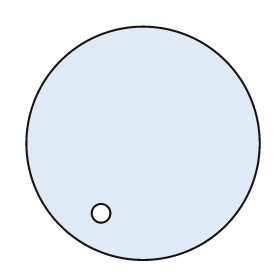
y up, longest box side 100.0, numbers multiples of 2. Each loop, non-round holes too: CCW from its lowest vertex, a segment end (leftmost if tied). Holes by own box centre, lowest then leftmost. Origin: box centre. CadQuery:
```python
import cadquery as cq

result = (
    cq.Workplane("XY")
    .moveTo(0.0, 0.0)
    .circle(50.0)
    .moveTo(-18.0, -30.0)
    .circle(4.0)
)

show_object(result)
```